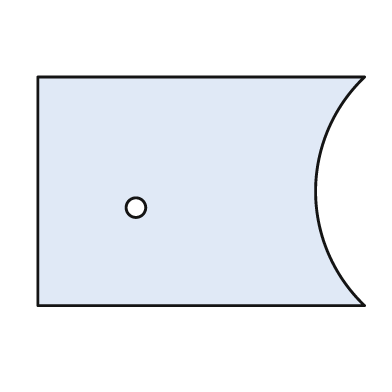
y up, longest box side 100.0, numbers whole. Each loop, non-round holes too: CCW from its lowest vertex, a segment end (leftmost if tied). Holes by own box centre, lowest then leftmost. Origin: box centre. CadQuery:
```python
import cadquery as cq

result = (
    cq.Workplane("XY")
    .moveTo(-50.0, -35.0)
    .lineTo(50.0, -35.0)
    .threePointArc((35.0, 0.0), (50.0, 35.0))
    .lineTo(-50.0, 35.0)
    .close()
    .moveTo(-20.0, -5.0)
    .circle(3.0)
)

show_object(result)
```